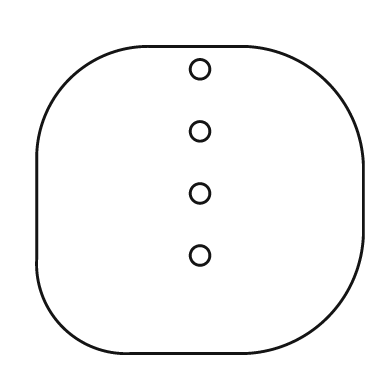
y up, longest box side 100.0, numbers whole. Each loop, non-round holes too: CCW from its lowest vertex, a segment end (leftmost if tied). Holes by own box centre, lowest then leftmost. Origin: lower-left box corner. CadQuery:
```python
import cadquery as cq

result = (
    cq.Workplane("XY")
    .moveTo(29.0, 0.0)
    .lineTo(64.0, 0.0)
    .threePointArc((89.0, 11.0), (100.0, 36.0))
    .lineTo(100.0, 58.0)
    .threePointArc((89.0, 83.0), (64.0, 94.0))
    .lineTo(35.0, 94.0)
    .threePointArc((10.0, 84.0), (0.0, 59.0))
    .lineTo(0.0, 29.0)
    .threePointArc((8.0, 8.0), (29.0, 0.0))
    .close()
    .moveTo(50.0, 30.0)
    .circle(3.0)
    .moveTo(50.0, 49.0)
    .circle(3.0)
    .moveTo(50.0, 68.0)
    .circle(3.0)
    .moveTo(50.0, 87.0)
    .circle(3.0)
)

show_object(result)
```